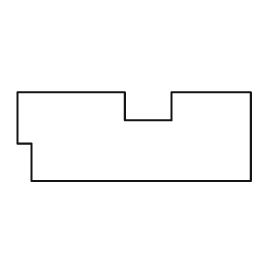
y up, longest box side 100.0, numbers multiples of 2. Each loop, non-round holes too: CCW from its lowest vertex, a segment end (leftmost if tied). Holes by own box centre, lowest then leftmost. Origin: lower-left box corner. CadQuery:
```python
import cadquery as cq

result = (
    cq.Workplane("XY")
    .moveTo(6.0, 0.0)
    .lineTo(100.0, 0.0)
    .lineTo(100.0, 38.0)
    .lineTo(66.0, 38.0)
    .lineTo(66.0, 26.0)
    .lineTo(46.0, 26.0)
    .lineTo(46.0, 38.0)
    .lineTo(0.0, 38.0)
    .lineTo(0.0, 16.0)
    .lineTo(6.0, 16.0)
    .close()
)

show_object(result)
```